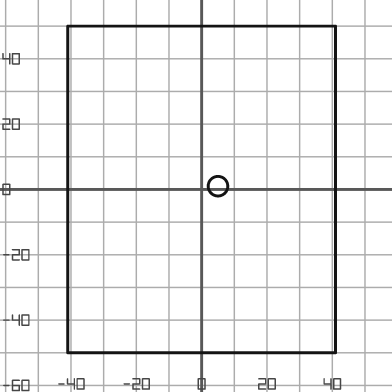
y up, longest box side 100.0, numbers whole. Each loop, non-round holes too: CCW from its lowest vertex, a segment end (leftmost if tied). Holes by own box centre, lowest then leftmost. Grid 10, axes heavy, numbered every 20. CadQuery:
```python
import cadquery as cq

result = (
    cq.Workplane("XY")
    .moveTo(-41.0, -50.0)
    .lineTo(41.0, -50.0)
    .lineTo(41.0, 50.0)
    .lineTo(-41.0, 50.0)
    .close()
    .moveTo(5.0, 1.0)
    .circle(3.0)
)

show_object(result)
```